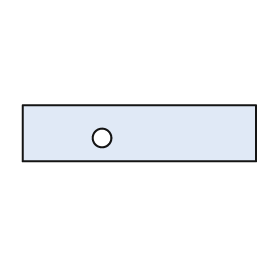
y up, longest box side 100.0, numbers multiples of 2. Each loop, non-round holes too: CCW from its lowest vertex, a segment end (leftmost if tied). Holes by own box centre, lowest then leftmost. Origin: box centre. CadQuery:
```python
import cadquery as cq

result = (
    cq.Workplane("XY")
    .moveTo(-50.0, -12.0)
    .lineTo(50.0, -12.0)
    .lineTo(50.0, 12.0)
    .lineTo(-50.0, 12.0)
    .close()
    .moveTo(-16.0, -2.0)
    .circle(4.0)
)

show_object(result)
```